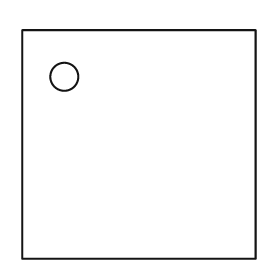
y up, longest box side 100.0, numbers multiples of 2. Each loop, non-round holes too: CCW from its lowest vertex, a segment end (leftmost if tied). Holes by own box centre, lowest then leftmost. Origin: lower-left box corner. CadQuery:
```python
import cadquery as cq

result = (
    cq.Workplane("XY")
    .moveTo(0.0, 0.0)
    .lineTo(100.0, 0.0)
    .lineTo(100.0, 98.0)
    .lineTo(0.0, 98.0)
    .close()
    .moveTo(18.0, 78.0)
    .circle(6.0)
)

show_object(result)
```